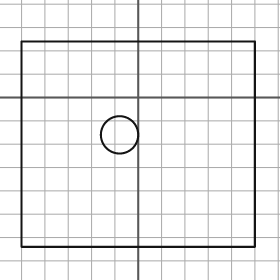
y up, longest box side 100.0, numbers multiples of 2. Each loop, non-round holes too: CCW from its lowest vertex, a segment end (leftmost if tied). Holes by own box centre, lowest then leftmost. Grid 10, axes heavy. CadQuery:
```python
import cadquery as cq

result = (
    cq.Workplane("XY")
    .moveTo(-50.0, -64.0)
    .lineTo(50.0, -64.0)
    .lineTo(50.0, 24.0)
    .lineTo(-50.0, 24.0)
    .close()
    .moveTo(-8.0, -16.0)
    .circle(8.0)
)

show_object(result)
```